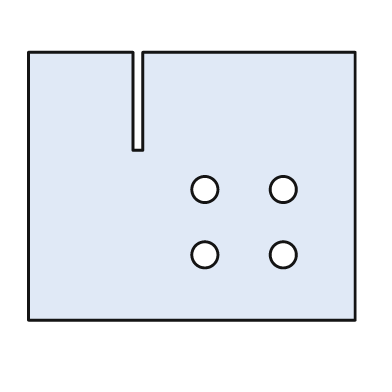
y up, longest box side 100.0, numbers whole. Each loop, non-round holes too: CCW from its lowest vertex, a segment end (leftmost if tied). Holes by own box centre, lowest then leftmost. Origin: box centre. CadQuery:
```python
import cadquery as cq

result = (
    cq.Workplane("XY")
    .moveTo(-50.0, -41.0)
    .lineTo(50.0, -41.0)
    .lineTo(50.0, 41.0)
    .lineTo(-15.0, 41.0)
    .lineTo(-15.0, 11.0)
    .lineTo(-18.0, 11.0)
    .lineTo(-18.0, 41.0)
    .lineTo(-50.0, 41.0)
    .close()
    .moveTo(4.0, -21.0)
    .circle(4.0)
    .moveTo(28.0, -21.0)
    .circle(4.0)
    .moveTo(4.0, -1.0)
    .circle(4.0)
    .moveTo(28.0, -1.0)
    .circle(4.0)
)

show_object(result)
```